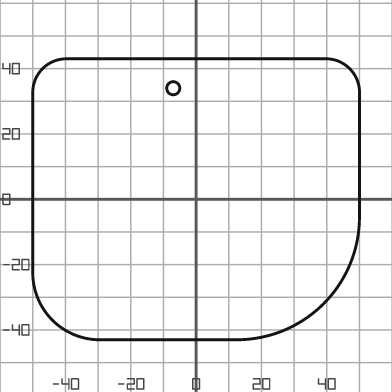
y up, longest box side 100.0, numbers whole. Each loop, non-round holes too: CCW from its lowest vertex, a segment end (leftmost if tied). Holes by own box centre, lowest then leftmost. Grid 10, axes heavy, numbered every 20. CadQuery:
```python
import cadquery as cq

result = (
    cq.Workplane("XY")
    .moveTo(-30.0, -43.0)
    .lineTo(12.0, -43.0)
    .threePointArc((39.0, -32.0), (50.0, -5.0))
    .lineTo(50.0, 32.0)
    .threePointArc((47.0, 40.0), (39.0, 43.0))
    .lineTo(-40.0, 43.0)
    .threePointArc((-47.0, 40.0), (-50.0, 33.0))
    .lineTo(-50.0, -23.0)
    .threePointArc((-44.0, -37.0), (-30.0, -43.0))
    .close()
    .moveTo(-7.0, 34.0)
    .circle(2.0)
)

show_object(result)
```